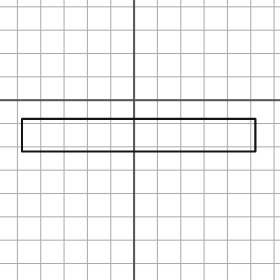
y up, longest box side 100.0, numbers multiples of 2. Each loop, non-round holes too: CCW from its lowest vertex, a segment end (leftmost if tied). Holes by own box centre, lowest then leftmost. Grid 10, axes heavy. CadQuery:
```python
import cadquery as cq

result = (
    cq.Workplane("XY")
    .moveTo(-48.0, -22.0)
    .lineTo(52.0, -22.0)
    .lineTo(52.0, -8.0)
    .lineTo(-48.0, -8.0)
    .close()
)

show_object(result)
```